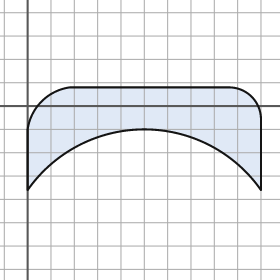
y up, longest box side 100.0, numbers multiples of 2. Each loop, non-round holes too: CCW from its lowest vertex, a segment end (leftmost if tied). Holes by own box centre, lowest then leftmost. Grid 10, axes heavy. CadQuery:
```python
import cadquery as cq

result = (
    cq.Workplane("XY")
    .moveTo(0.0, -36.0)
    .threePointArc((50.0, -10.0), (100.0, -36.0))
    .lineTo(100.0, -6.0)
    .threePointArc((96.0, 4.0), (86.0, 8.0))
    .lineTo(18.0, 8.0)
    .threePointArc((6.0, 2.0), (0.0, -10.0))
    .close()
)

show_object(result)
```